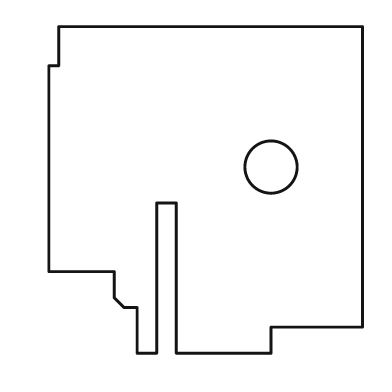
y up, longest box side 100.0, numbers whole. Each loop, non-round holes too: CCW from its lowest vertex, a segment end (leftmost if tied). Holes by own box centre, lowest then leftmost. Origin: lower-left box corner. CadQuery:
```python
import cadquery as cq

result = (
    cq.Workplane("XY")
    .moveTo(27.0, 0.0)
    .lineTo(33.0, 0.0)
    .lineTo(33.0, 46.0)
    .lineTo(39.0, 46.0)
    .lineTo(39.0, 0.0)
    .lineTo(68.0, 0.0)
    .lineTo(68.0, 8.0)
    .lineTo(96.0, 8.0)
    .lineTo(96.0, 100.0)
    .lineTo(3.0, 100.0)
    .lineTo(3.0, 88.0)
    .lineTo(0.0, 88.0)
    .lineTo(0.0, 25.0)
    .lineTo(20.0, 25.0)
    .lineTo(20.0, 17.0)
    .lineTo(23.0, 14.0)
    .lineTo(27.0, 14.0)
    .close()
    .moveTo(68.0, 57.0)
    .circle(8.0)
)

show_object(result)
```